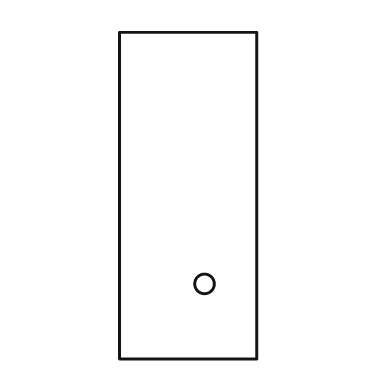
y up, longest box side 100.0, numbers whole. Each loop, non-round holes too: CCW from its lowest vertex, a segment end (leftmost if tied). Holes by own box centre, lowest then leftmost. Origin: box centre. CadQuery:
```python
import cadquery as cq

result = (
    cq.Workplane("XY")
    .moveTo(-21.0, -50.0)
    .lineTo(21.0, -50.0)
    .lineTo(21.0, 50.0)
    .lineTo(-21.0, 50.0)
    .close()
    .moveTo(5.0, -27.0)
    .circle(3.0)
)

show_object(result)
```